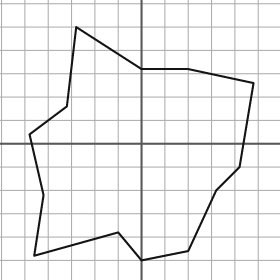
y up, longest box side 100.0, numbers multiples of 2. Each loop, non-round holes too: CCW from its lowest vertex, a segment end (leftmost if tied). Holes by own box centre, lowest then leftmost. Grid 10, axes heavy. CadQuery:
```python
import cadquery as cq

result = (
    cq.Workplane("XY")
    .moveTo(0.0, -50.0)
    .lineTo(20.0, -46.0)
    .lineTo(32.0, -20.0)
    .lineTo(42.0, -10.0)
    .lineTo(48.0, 26.0)
    .lineTo(20.0, 32.0)
    .lineTo(0.0, 32.0)
    .lineTo(-28.0, 50.0)
    .lineTo(-32.0, 16.0)
    .lineTo(-48.0, 4.0)
    .lineTo(-42.0, -22.0)
    .lineTo(-46.0, -48.0)
    .lineTo(-10.0, -38.0)
    .close()
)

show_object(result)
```